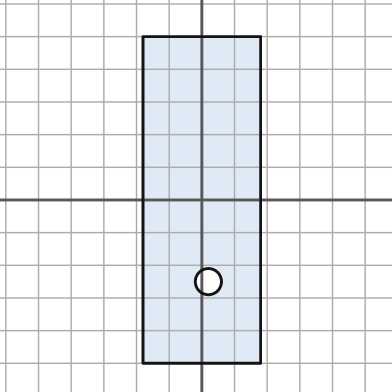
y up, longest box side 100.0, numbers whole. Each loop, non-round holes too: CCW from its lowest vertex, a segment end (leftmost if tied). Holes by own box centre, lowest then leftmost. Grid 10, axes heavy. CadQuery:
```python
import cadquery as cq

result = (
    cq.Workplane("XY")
    .moveTo(-18.0, -50.0)
    .lineTo(18.0, -50.0)
    .lineTo(18.0, 50.0)
    .lineTo(-18.0, 50.0)
    .close()
    .moveTo(2.0, -25.0)
    .circle(4.0)
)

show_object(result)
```